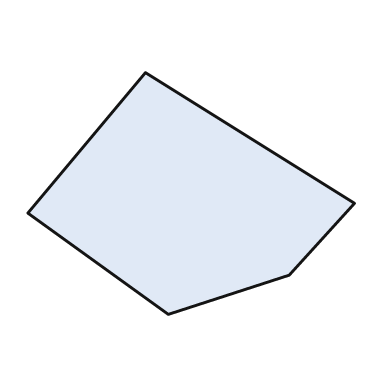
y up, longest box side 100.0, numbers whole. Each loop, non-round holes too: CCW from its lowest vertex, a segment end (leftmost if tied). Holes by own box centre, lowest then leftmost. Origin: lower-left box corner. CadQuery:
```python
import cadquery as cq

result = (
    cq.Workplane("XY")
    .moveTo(43.0, 0.0)
    .lineTo(80.0, 12.0)
    .lineTo(100.0, 34.0)
    .lineTo(36.0, 74.0)
    .lineTo(0.0, 31.0)
    .close()
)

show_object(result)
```